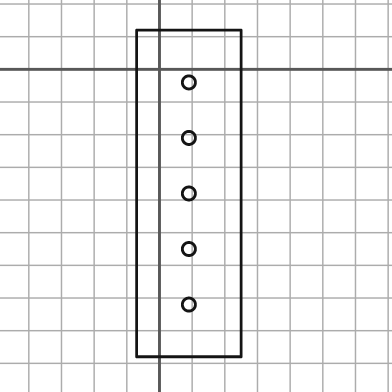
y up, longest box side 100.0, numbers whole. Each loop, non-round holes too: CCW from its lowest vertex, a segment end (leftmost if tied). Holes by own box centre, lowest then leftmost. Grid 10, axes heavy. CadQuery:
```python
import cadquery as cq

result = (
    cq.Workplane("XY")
    .moveTo(-7.0, -88.0)
    .lineTo(25.0, -88.0)
    .lineTo(25.0, 12.0)
    .lineTo(-7.0, 12.0)
    .close()
    .moveTo(9.0, -72.0)
    .circle(2.0)
    .moveTo(9.0, -55.0)
    .circle(2.0)
    .moveTo(9.0, -38.0)
    .circle(2.0)
    .moveTo(9.0, -21.0)
    .circle(2.0)
    .moveTo(9.0, -4.0)
    .circle(2.0)
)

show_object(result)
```